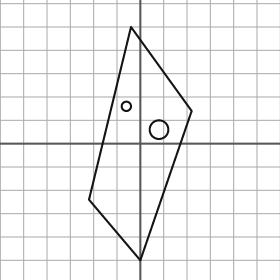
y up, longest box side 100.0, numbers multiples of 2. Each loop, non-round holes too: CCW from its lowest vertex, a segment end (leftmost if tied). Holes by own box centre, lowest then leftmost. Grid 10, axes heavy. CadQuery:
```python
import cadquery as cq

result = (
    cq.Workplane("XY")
    .moveTo(0.0, -50.0)
    .lineTo(22.0, 14.0)
    .lineTo(-4.0, 50.0)
    .lineTo(-22.0, -24.0)
    .close()
    .moveTo(8.0, 6.0)
    .circle(4.0)
    .moveTo(-6.0, 16.0)
    .circle(2.0)
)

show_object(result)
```